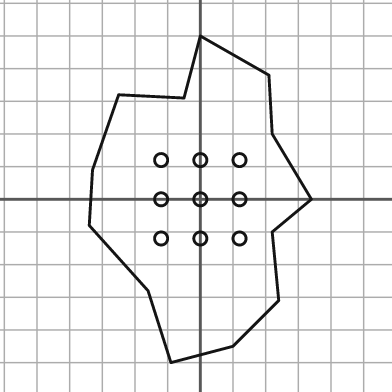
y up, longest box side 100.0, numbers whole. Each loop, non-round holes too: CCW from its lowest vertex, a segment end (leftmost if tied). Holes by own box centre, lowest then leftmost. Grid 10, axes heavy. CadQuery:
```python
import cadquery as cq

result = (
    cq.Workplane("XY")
    .moveTo(-9.0, -50.0)
    .lineTo(10.0, -45.0)
    .lineTo(24.0, -31.0)
    .lineTo(22.0, -10.0)
    .lineTo(34.0, 0.0)
    .lineTo(22.0, 20.0)
    .lineTo(21.0, 38.0)
    .lineTo(0.0, 50.0)
    .lineTo(-5.0, 31.0)
    .lineTo(-25.0, 32.0)
    .lineTo(-33.0, 9.0)
    .lineTo(-34.0, -8.0)
    .lineTo(-16.0, -28.0)
    .close()
    .moveTo(-12.0, -12.0)
    .circle(2.0)
    .moveTo(0.0, -12.0)
    .circle(2.0)
    .moveTo(12.0, -12.0)
    .circle(2.0)
    .moveTo(-12.0, 0.0)
    .circle(2.0)
    .moveTo(0.0, 0.0)
    .circle(2.0)
    .moveTo(12.0, 0.0)
    .circle(2.0)
    .moveTo(-12.0, 12.0)
    .circle(2.0)
    .moveTo(0.0, 12.0)
    .circle(2.0)
    .moveTo(12.0, 12.0)
    .circle(2.0)
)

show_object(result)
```